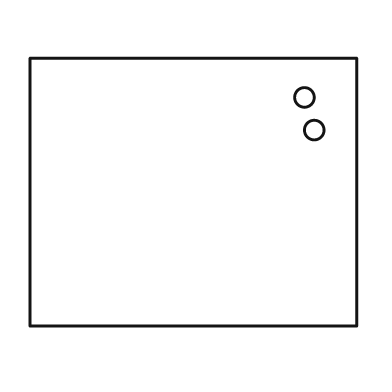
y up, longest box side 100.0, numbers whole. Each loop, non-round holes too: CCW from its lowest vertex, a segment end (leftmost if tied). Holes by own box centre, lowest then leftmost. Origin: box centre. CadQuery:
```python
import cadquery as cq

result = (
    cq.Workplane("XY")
    .moveTo(-50.0, -41.0)
    .lineTo(50.0, -41.0)
    .lineTo(50.0, 41.0)
    .lineTo(-50.0, 41.0)
    .close()
    .moveTo(37.0, 19.0)
    .circle(3.0)
    .moveTo(34.0, 29.0)
    .circle(3.0)
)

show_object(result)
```